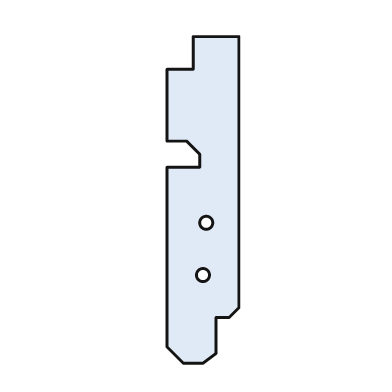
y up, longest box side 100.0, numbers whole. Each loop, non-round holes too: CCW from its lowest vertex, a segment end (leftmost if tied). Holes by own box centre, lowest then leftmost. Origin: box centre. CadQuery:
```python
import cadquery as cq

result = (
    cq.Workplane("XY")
    .moveTo(-6.0, -50.0)
    .lineTo(0.0, -50.0)
    .lineTo(4.0, -47.0)
    .lineTo(4.0, -36.0)
    .lineTo(8.0, -36.0)
    .lineTo(11.0, -33.0)
    .lineTo(11.0, 50.0)
    .lineTo(-3.0, 50.0)
    .lineTo(-3.0, 40.0)
    .lineTo(-11.0, 40.0)
    .lineTo(-11.0, 18.0)
    .lineTo(-5.0, 18.0)
    .lineTo(-1.0, 14.0)
    .lineTo(-1.0, 10.0)
    .lineTo(-11.0, 10.0)
    .lineTo(-11.0, -45.0)
    .close()
    .moveTo(0.0, -23.0)
    .circle(2.0)
    .moveTo(1.0, -7.0)
    .circle(2.0)
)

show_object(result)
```